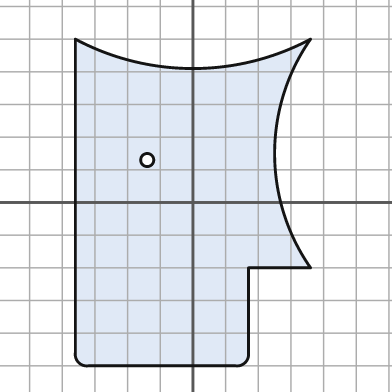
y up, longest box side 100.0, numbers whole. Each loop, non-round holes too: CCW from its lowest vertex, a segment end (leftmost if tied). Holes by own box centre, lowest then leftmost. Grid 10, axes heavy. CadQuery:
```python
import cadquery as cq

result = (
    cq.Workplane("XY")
    .moveTo(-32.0, -50.0)
    .lineTo(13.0, -50.0)
    .threePointArc((16.0, -49.0), (17.0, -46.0))
    .lineTo(17.0, -20.0)
    .lineTo(36.0, -20.0)
    .threePointArc((25.0, 15.0), (36.0, 50.0))
    .threePointArc((0.0, 41.0), (-36.0, 50.0))
    .lineTo(-36.0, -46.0)
    .threePointArc((-35.0, -49.0), (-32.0, -50.0))
    .close()
    .moveTo(-14.0, 13.0)
    .circle(2.0)
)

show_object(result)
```